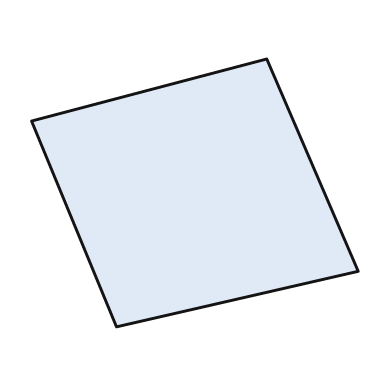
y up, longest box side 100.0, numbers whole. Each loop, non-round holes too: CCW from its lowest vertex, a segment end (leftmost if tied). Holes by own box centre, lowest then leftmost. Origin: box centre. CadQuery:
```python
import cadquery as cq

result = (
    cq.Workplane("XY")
    .moveTo(-24.0, -41.0)
    .lineTo(50.0, -24.0)
    .lineTo(22.0, 41.0)
    .lineTo(-50.0, 22.0)
    .close()
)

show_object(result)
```